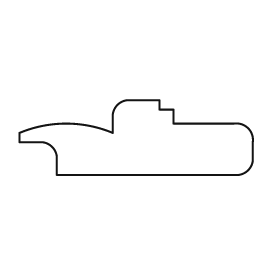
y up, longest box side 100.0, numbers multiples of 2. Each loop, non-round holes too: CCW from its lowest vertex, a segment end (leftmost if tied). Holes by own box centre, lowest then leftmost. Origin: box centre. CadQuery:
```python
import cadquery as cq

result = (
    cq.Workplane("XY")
    .moveTo(-34.0, -16.0)
    .lineTo(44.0, -16.0)
    .threePointArc((48.0, -14.0), (50.0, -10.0))
    .lineTo(50.0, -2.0)
    .threePointArc((48.0, 4.0), (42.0, 6.0))
    .lineTo(16.0, 6.0)
    .lineTo(16.0, 12.0)
    .lineTo(10.0, 12.0)
    .lineTo(10.0, 16.0)
    .lineTo(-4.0, 16.0)
    .threePointArc((-8.0, 14.0), (-10.0, 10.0))
    .lineTo(-10.0, 2.0)
    .threePointArc((-30.0, 6.0), (-50.0, 2.0))
    .lineTo(-50.0, -2.0)
    .lineTo(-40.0, -2.0)
    .threePointArc((-36.0, -4.0), (-34.0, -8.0))
    .close()
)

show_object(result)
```